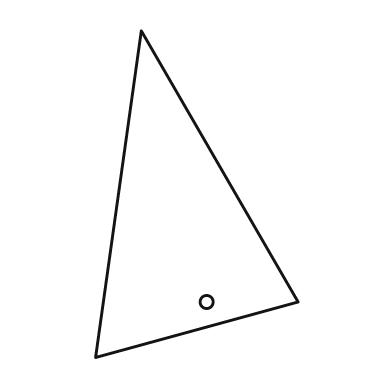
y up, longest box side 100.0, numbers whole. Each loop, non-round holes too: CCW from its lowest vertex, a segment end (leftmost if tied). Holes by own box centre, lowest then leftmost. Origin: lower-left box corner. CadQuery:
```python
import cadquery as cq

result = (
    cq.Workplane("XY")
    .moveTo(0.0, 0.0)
    .lineTo(62.0, 17.0)
    .lineTo(14.0, 100.0)
    .close()
    .moveTo(34.0, 17.0)
    .circle(2.0)
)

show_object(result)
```